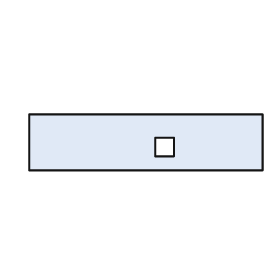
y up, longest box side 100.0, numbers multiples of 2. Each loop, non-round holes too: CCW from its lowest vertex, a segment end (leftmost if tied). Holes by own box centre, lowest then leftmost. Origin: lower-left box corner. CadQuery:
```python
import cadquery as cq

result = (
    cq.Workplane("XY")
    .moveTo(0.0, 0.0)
    .lineTo(100.0, 0.0)
    .lineTo(100.0, 24.0)
    .lineTo(0.0, 24.0)
    .close()
    .moveTo(54.0, 6.0)
    .lineTo(62.0, 6.0)
    .lineTo(62.0, 14.0)
    .lineTo(54.0, 14.0)
    .close()
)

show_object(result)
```